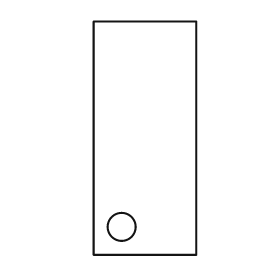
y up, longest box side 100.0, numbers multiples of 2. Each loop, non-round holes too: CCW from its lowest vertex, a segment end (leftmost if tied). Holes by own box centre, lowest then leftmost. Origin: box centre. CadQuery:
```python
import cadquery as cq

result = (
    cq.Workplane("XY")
    .moveTo(-22.0, -50.0)
    .lineTo(22.0, -50.0)
    .lineTo(22.0, 50.0)
    .lineTo(-22.0, 50.0)
    .close()
    .moveTo(-10.0, -38.0)
    .circle(6.0)
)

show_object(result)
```